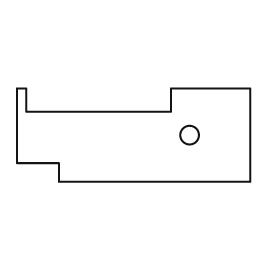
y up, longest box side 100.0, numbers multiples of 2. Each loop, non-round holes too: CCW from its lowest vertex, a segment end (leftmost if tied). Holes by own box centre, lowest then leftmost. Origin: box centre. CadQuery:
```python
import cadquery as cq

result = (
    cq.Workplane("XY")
    .moveTo(-32.0, -20.0)
    .lineTo(50.0, -20.0)
    .lineTo(50.0, 20.0)
    .lineTo(16.0, 20.0)
    .lineTo(16.0, 10.0)
    .lineTo(-46.0, 10.0)
    .lineTo(-46.0, 20.0)
    .lineTo(-50.0, 20.0)
    .lineTo(-50.0, -12.0)
    .lineTo(-32.0, -12.0)
    .close()
    .moveTo(24.0, 0.0)
    .circle(4.0)
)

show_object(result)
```